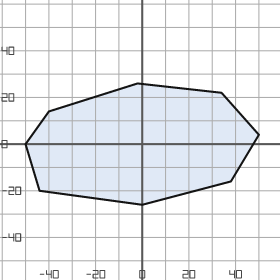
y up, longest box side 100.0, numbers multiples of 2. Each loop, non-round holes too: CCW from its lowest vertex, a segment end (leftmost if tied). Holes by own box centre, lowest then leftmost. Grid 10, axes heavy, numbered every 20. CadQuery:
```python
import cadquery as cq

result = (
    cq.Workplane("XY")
    .moveTo(0.0, -26.0)
    .lineTo(38.0, -16.0)
    .lineTo(50.0, 4.0)
    .lineTo(34.0, 22.0)
    .lineTo(-2.0, 26.0)
    .lineTo(-40.0, 14.0)
    .lineTo(-50.0, 0.0)
    .lineTo(-44.0, -20.0)
    .close()
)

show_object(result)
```